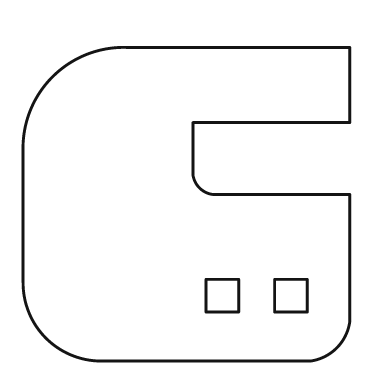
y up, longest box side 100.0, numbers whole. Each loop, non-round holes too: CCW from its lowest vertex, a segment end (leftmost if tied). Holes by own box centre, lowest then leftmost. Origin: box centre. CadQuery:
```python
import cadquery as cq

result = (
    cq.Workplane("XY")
    .moveTo(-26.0, -48.0)
    .lineTo(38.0, -48.0)
    .threePointArc((46.0, -44.0), (50.0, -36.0))
    .lineTo(50.0, 3.0)
    .lineTo(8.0, 3.0)
    .threePointArc((4.0, 5.0), (2.0, 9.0))
    .lineTo(2.0, 25.0)
    .lineTo(50.0, 25.0)
    .lineTo(50.0, 48.0)
    .lineTo(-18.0, 48.0)
    .threePointArc((-41.0, 39.0), (-50.0, 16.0))
    .lineTo(-50.0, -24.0)
    .threePointArc((-43.0, -41.0), (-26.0, -48.0))
    .close()
    .moveTo(6.0, -33.0)
    .lineTo(16.0, -33.0)
    .lineTo(16.0, -23.0)
    .lineTo(6.0, -23.0)
    .close()
    .moveTo(27.0, -33.0)
    .lineTo(37.0, -33.0)
    .lineTo(37.0, -23.0)
    .lineTo(27.0, -23.0)
    .close()
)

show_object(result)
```